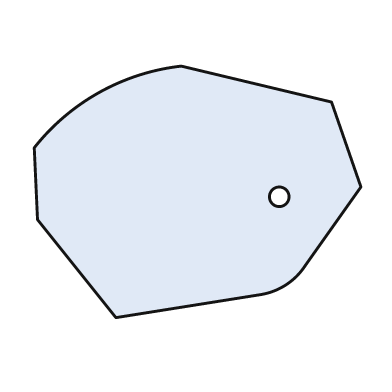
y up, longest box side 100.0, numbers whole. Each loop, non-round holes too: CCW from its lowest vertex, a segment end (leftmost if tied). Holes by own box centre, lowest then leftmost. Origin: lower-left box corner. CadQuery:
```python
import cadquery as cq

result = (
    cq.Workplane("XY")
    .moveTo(25.0, 0.0)
    .lineTo(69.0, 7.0)
    .threePointArc((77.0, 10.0), (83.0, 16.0))
    .lineTo(100.0, 40.0)
    .lineTo(91.0, 66.0)
    .lineTo(45.0, 77.0)
    .threePointArc((20.0, 69.0), (0.0, 52.0))
    .lineTo(1.0, 30.0)
    .close()
    .moveTo(75.0, 37.0)
    .circle(3.0)
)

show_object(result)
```